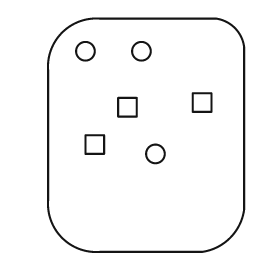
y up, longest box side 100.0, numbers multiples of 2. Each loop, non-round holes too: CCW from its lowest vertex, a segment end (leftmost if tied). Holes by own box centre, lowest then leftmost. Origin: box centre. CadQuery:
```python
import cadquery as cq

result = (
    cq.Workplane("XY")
    .moveTo(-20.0, -50.0)
    .lineTo(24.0, -50.0)
    .threePointArc((36.0, -44.0), (42.0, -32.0))
    .lineTo(42.0, 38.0)
    .threePointArc((38.0, 46.0), (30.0, 50.0))
    .lineTo(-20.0, 50.0)
    .threePointArc((-36.0, 44.0), (-42.0, 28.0))
    .lineTo(-42.0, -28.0)
    .threePointArc((-36.0, -44.0), (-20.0, -50.0))
    .close()
    .moveTo(4.0, -8.0)
    .circle(4.0)
    .moveTo(-26.0, -8.0)
    .lineTo(-18.0, -8.0)
    .lineTo(-18.0, 0.0)
    .lineTo(-26.0, 0.0)
    .close()
    .moveTo(-12.0, 8.0)
    .lineTo(-4.0, 8.0)
    .lineTo(-4.0, 16.0)
    .lineTo(-12.0, 16.0)
    .close()
    .moveTo(20.0, 10.0)
    .lineTo(28.0, 10.0)
    .lineTo(28.0, 18.0)
    .lineTo(20.0, 18.0)
    .close()
    .moveTo(-26.0, 36.0)
    .circle(4.0)
    .moveTo(-2.0, 36.0)
    .circle(4.0)
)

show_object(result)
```